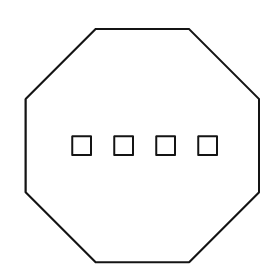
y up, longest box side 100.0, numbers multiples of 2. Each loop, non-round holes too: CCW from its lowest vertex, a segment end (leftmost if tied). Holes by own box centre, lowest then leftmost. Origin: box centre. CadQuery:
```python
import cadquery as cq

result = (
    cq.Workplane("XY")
    .moveTo(-20.0, -50.0)
    .lineTo(20.0, -50.0)
    .lineTo(50.0, -20.0)
    .lineTo(50.0, 20.0)
    .lineTo(20.0, 50.0)
    .lineTo(-20.0, 50.0)
    .lineTo(-50.0, 20.0)
    .lineTo(-50.0, -20.0)
    .close()
    .moveTo(-30.0, -4.0)
    .lineTo(-22.0, -4.0)
    .lineTo(-22.0, 4.0)
    .lineTo(-30.0, 4.0)
    .close()
    .moveTo(-12.0, -4.0)
    .lineTo(-4.0, -4.0)
    .lineTo(-4.0, 4.0)
    .lineTo(-12.0, 4.0)
    .close()
    .moveTo(6.0, -4.0)
    .lineTo(14.0, -4.0)
    .lineTo(14.0, 4.0)
    .lineTo(6.0, 4.0)
    .close()
    .moveTo(24.0, -4.0)
    .lineTo(32.0, -4.0)
    .lineTo(32.0, 4.0)
    .lineTo(24.0, 4.0)
    .close()
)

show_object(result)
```